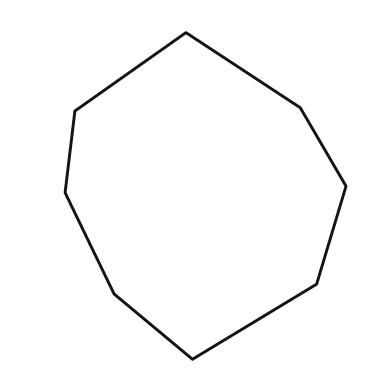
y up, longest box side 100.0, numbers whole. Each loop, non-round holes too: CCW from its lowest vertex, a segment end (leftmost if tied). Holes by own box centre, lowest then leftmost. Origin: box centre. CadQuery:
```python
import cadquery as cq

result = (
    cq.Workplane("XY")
    .moveTo(-4.0, -50.0)
    .lineTo(34.0, -27.0)
    .lineTo(43.0, 3.0)
    .lineTo(29.0, 27.0)
    .lineTo(-6.0, 50.0)
    .lineTo(-40.0, 26.0)
    .lineTo(-43.0, 1.0)
    .lineTo(-28.0, -30.0)
    .close()
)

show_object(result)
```